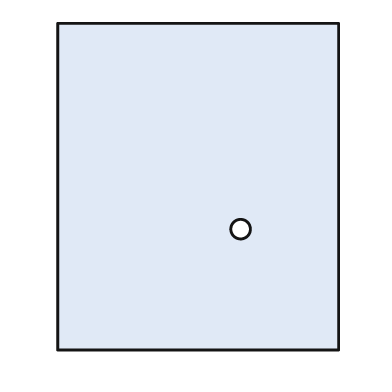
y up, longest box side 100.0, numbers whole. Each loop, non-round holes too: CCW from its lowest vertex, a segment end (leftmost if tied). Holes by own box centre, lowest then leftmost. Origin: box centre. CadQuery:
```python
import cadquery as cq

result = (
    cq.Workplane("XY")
    .moveTo(-43.0, -50.0)
    .lineTo(43.0, -50.0)
    .lineTo(43.0, 50.0)
    .lineTo(-43.0, 50.0)
    .close()
    .moveTo(13.0, -13.0)
    .circle(3.0)
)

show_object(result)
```